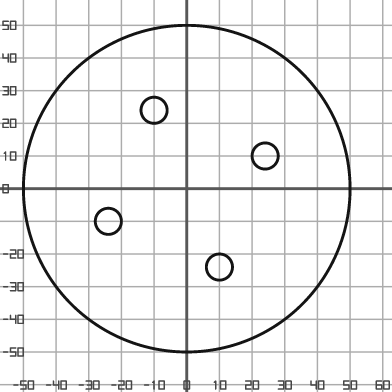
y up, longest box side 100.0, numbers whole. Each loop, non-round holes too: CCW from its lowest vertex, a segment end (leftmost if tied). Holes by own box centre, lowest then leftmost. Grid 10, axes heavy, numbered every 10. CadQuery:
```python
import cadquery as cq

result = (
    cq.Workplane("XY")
    .moveTo(0.0, 0.0)
    .circle(50.0)
    .moveTo(10.0, -24.0)
    .circle(4.0)
    .moveTo(-24.0, -10.0)
    .circle(4.0)
    .moveTo(24.0, 10.0)
    .circle(4.0)
    .moveTo(-10.0, 24.0)
    .circle(4.0)
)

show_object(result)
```